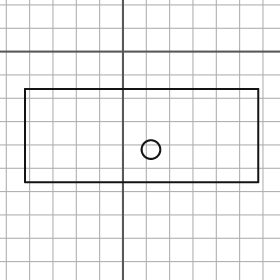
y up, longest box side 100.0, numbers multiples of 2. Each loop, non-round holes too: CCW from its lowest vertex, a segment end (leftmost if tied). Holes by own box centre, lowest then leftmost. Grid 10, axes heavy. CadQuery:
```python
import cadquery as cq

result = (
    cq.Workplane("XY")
    .moveTo(-42.0, -56.0)
    .lineTo(58.0, -56.0)
    .lineTo(58.0, -16.0)
    .lineTo(-42.0, -16.0)
    .close()
    .moveTo(12.0, -42.0)
    .circle(4.0)
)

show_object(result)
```